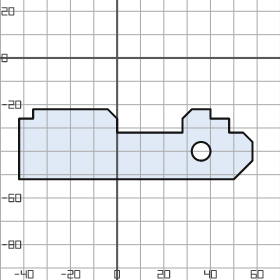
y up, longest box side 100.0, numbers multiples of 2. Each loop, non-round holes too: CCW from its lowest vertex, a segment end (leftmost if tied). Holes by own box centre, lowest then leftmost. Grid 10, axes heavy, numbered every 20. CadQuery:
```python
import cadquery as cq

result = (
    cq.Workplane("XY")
    .moveTo(-42.0, -52.0)
    .lineTo(50.0, -52.0)
    .lineTo(58.0, -44.0)
    .lineTo(58.0, -36.0)
    .lineTo(54.0, -32.0)
    .lineTo(48.0, -32.0)
    .lineTo(48.0, -26.0)
    .lineTo(40.0, -26.0)
    .lineTo(40.0, -22.0)
    .lineTo(32.0, -22.0)
    .lineTo(28.0, -26.0)
    .lineTo(28.0, -32.0)
    .lineTo(0.0, -32.0)
    .lineTo(0.0, -26.0)
    .lineTo(-4.0, -22.0)
    .lineTo(-36.0, -22.0)
    .lineTo(-36.0, -26.0)
    .lineTo(-42.0, -26.0)
    .close()
    .moveTo(36.0, -40.0)
    .circle(4.0)
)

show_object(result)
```